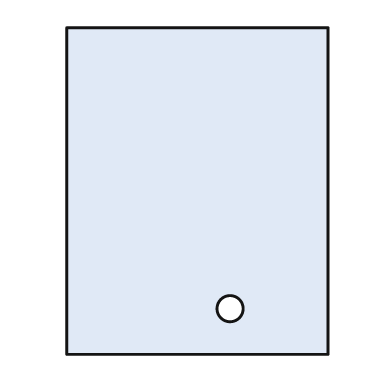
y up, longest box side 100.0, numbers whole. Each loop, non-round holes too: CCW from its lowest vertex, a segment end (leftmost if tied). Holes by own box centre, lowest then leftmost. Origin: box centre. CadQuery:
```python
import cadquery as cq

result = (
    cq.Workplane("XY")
    .moveTo(-40.0, -50.0)
    .lineTo(40.0, -50.0)
    .lineTo(40.0, 50.0)
    .lineTo(-40.0, 50.0)
    .close()
    .moveTo(10.0, -36.0)
    .circle(4.0)
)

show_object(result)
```